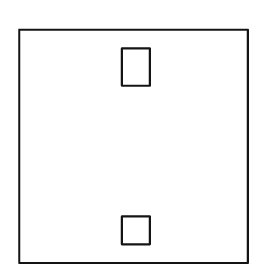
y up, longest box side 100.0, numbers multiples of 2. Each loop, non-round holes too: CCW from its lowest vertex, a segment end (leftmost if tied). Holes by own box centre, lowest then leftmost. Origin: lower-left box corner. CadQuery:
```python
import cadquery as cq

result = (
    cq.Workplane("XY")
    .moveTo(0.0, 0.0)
    .lineTo(98.0, 0.0)
    .lineTo(98.0, 100.0)
    .lineTo(0.0, 100.0)
    .close()
    .moveTo(44.0, 8.0)
    .lineTo(56.0, 8.0)
    .lineTo(56.0, 20.0)
    .lineTo(44.0, 20.0)
    .close()
    .moveTo(44.0, 76.0)
    .lineTo(56.0, 76.0)
    .lineTo(56.0, 92.0)
    .lineTo(44.0, 92.0)
    .close()
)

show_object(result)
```